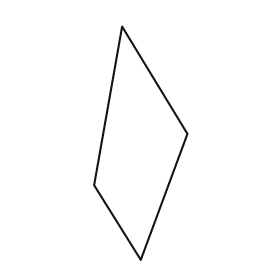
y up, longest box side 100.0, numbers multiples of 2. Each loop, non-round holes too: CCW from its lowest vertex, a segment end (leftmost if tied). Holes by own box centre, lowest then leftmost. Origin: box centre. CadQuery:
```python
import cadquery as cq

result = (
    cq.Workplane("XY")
    .moveTo(0.0, -50.0)
    .lineTo(20.0, 4.0)
    .lineTo(-8.0, 50.0)
    .lineTo(-20.0, -18.0)
    .close()
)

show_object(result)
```